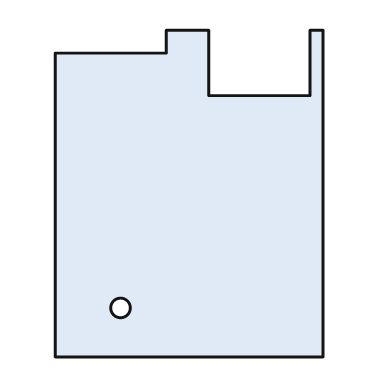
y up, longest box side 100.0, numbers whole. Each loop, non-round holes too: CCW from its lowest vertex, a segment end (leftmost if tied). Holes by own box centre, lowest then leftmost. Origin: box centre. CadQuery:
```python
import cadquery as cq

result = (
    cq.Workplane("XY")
    .moveTo(-41.0, -50.0)
    .lineTo(41.0, -50.0)
    .lineTo(41.0, 50.0)
    .lineTo(37.0, 50.0)
    .lineTo(37.0, 30.0)
    .lineTo(6.0, 30.0)
    .lineTo(6.0, 50.0)
    .lineTo(-7.0, 50.0)
    .lineTo(-7.0, 43.0)
    .lineTo(-41.0, 43.0)
    .close()
    .moveTo(-21.0, -35.0)
    .circle(3.0)
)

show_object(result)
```